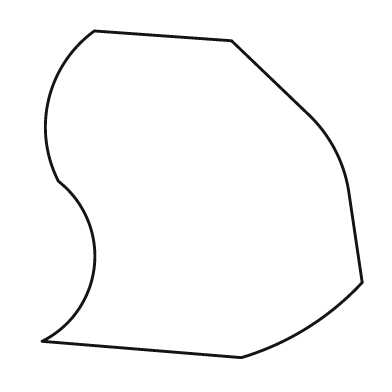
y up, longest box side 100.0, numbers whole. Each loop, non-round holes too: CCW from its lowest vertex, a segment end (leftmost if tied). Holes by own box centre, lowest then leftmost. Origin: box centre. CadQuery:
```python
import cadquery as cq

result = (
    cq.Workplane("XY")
    .moveTo(12.0, -50.0)
    .threePointArc((32.0, -41.0), (49.0, -27.0))
    .lineTo(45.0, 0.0)
    .threePointArc((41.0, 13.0), (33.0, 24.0))
    .lineTo(9.0, 47.0)
    .lineTo(-33.0, 50.0)
    .threePointArc((-47.0, 29.0), (-44.0, 4.0))
    .threePointArc((-33.0, -22.0), (-49.0, -45.0))
    .close()
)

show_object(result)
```